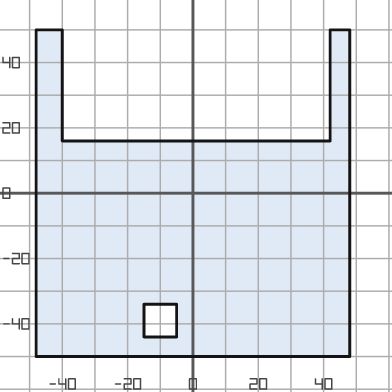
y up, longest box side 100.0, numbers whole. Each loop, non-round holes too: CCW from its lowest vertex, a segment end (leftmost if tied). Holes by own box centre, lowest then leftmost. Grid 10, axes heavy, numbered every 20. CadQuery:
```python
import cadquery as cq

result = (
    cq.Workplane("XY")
    .moveTo(-48.0, -50.0)
    .lineTo(48.0, -50.0)
    .lineTo(48.0, 50.0)
    .lineTo(42.0, 50.0)
    .lineTo(42.0, 16.0)
    .lineTo(-40.0, 16.0)
    .lineTo(-40.0, 50.0)
    .lineTo(-48.0, 50.0)
    .close()
    .moveTo(-15.0, -44.0)
    .lineTo(-5.0, -44.0)
    .lineTo(-5.0, -34.0)
    .lineTo(-15.0, -34.0)
    .close()
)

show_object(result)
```